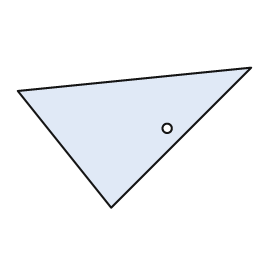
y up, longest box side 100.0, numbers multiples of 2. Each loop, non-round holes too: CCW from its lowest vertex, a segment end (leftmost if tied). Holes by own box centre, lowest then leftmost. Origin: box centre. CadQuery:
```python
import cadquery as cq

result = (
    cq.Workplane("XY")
    .moveTo(-10.0, -30.0)
    .lineTo(50.0, 30.0)
    .lineTo(-50.0, 20.0)
    .close()
    .moveTo(14.0, 4.0)
    .circle(2.0)
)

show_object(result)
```